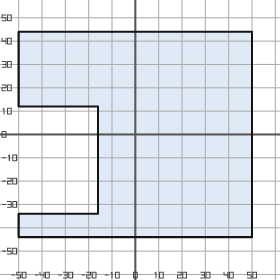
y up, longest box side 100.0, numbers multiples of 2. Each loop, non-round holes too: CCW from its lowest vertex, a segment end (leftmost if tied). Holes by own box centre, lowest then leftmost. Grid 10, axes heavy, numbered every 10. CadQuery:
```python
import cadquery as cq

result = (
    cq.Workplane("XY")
    .moveTo(-50.0, -44.0)
    .lineTo(50.0, -44.0)
    .lineTo(50.0, 44.0)
    .lineTo(-50.0, 44.0)
    .lineTo(-50.0, 12.0)
    .lineTo(-16.0, 12.0)
    .lineTo(-16.0, -34.0)
    .lineTo(-50.0, -34.0)
    .close()
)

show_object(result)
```